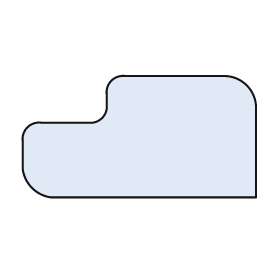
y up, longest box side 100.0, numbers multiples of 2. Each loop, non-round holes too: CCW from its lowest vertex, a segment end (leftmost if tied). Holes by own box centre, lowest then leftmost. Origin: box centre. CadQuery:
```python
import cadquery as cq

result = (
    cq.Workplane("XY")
    .moveTo(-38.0, -26.0)
    .lineTo(50.0, -26.0)
    .lineTo(50.0, 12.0)
    .threePointArc((46.0, 22.0), (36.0, 26.0))
    .lineTo(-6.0, 26.0)
    .threePointArc((-12.0, 24.0), (-14.0, 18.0))
    .lineTo(-14.0, 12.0)
    .threePointArc((-16.0, 8.0), (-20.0, 6.0))
    .lineTo(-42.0, 6.0)
    .threePointArc((-48.0, 4.0), (-50.0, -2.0))
    .lineTo(-50.0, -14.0)
    .threePointArc((-46.0, -22.0), (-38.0, -26.0))
    .close()
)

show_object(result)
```